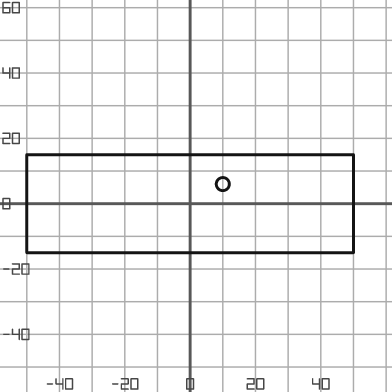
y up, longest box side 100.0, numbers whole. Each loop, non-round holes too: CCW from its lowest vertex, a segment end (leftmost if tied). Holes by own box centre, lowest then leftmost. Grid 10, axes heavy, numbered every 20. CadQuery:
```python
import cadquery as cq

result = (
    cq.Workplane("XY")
    .moveTo(-50.0, -15.0)
    .lineTo(50.0, -15.0)
    .lineTo(50.0, 15.0)
    .lineTo(-50.0, 15.0)
    .close()
    .moveTo(10.0, 6.0)
    .circle(2.0)
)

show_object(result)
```